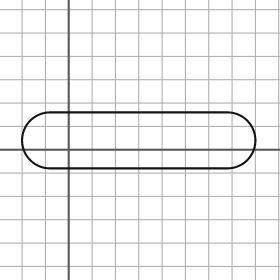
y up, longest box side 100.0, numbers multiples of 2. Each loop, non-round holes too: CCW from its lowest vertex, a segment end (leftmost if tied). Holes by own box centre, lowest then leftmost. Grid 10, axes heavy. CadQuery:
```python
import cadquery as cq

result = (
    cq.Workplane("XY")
    .moveTo(-8.0, -8.0)
    .lineTo(68.0, -8.0)
    .threePointArc((80.0, 4.0), (68.0, 16.0))
    .lineTo(-8.0, 16.0)
    .threePointArc((-20.0, 4.0), (-8.0, -8.0))
    .close()
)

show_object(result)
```